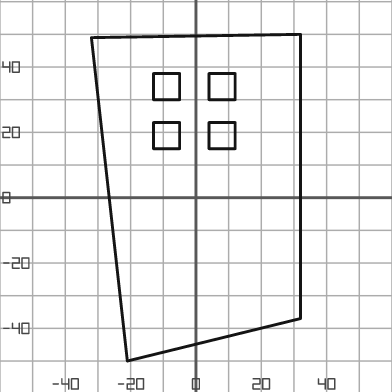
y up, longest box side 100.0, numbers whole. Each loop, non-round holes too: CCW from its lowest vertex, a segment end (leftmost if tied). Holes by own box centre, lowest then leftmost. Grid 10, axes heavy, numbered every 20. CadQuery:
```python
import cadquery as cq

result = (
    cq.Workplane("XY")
    .moveTo(-21.0, -50.0)
    .lineTo(32.0, -37.0)
    .lineTo(32.0, 50.0)
    .lineTo(-32.0, 49.0)
    .close()
    .moveTo(-13.0, 15.0)
    .lineTo(-5.0, 15.0)
    .lineTo(-5.0, 23.0)
    .lineTo(-13.0, 23.0)
    .close()
    .moveTo(4.0, 15.0)
    .lineTo(12.0, 15.0)
    .lineTo(12.0, 23.0)
    .lineTo(4.0, 23.0)
    .close()
    .moveTo(-13.0, 30.0)
    .lineTo(-5.0, 30.0)
    .lineTo(-5.0, 38.0)
    .lineTo(-13.0, 38.0)
    .close()
    .moveTo(4.0, 30.0)
    .lineTo(12.0, 30.0)
    .lineTo(12.0, 38.0)
    .lineTo(4.0, 38.0)
    .close()
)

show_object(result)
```